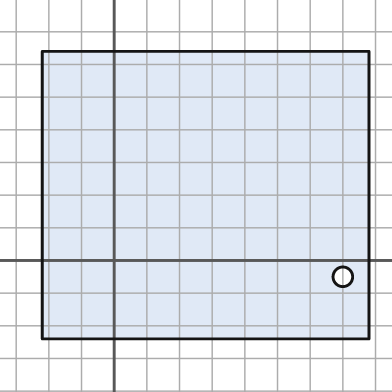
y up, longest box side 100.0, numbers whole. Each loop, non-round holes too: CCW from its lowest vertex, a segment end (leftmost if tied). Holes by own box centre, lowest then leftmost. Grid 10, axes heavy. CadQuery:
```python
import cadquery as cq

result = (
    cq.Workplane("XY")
    .moveTo(-22.0, -24.0)
    .lineTo(78.0, -24.0)
    .lineTo(78.0, 64.0)
    .lineTo(-22.0, 64.0)
    .close()
    .moveTo(70.0, -5.0)
    .circle(3.0)
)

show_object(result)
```